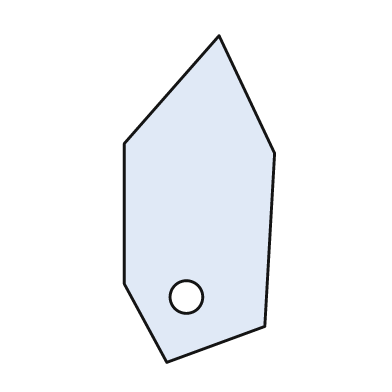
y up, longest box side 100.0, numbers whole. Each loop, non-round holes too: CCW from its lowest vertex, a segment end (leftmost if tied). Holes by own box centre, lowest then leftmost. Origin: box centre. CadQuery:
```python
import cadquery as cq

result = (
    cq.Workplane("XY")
    .moveTo(-10.0, -50.0)
    .lineTo(20.0, -39.0)
    .lineTo(23.0, 14.0)
    .lineTo(6.0, 50.0)
    .lineTo(-23.0, 17.0)
    .lineTo(-23.0, -26.0)
    .close()
    .moveTo(-4.0, -30.0)
    .circle(5.0)
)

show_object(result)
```